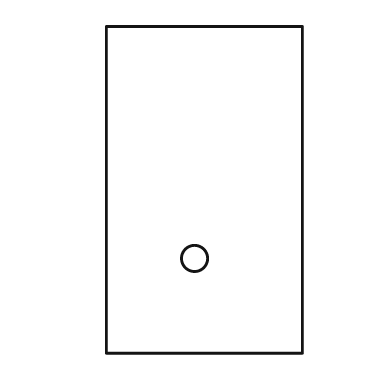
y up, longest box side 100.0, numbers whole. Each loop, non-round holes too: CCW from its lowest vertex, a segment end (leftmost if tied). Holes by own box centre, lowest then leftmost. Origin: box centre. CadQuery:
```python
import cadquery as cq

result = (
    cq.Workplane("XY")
    .moveTo(-30.0, -50.0)
    .lineTo(30.0, -50.0)
    .lineTo(30.0, 50.0)
    .lineTo(-30.0, 50.0)
    .close()
    .moveTo(-3.0, -21.0)
    .circle(4.0)
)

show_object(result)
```